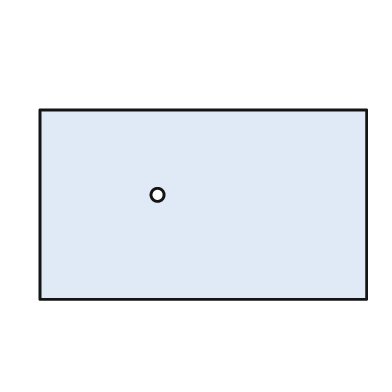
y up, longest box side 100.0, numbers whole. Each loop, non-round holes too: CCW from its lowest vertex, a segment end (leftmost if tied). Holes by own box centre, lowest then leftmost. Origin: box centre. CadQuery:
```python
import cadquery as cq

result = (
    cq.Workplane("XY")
    .moveTo(-50.0, -29.0)
    .lineTo(50.0, -29.0)
    .lineTo(50.0, 29.0)
    .lineTo(-50.0, 29.0)
    .close()
    .moveTo(-14.0, 3.0)
    .circle(2.0)
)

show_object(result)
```